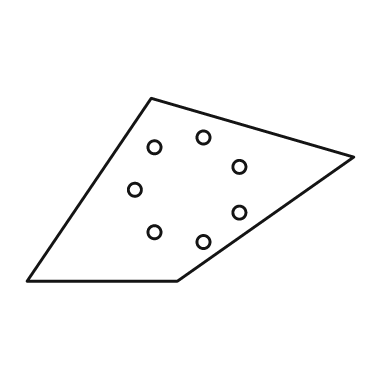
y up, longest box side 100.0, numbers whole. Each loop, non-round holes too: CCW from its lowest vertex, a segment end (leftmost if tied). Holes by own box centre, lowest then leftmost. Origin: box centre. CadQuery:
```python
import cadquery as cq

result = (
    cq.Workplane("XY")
    .moveTo(-50.0, -28.0)
    .lineTo(-4.0, -28.0)
    .lineTo(50.0, 10.0)
    .lineTo(-12.0, 28.0)
    .close()
    .moveTo(4.0, -16.0)
    .circle(2.0)
    .moveTo(-11.0, -13.0)
    .circle(2.0)
    .moveTo(15.0, -7.0)
    .circle(2.0)
    .moveTo(-17.0, 0.0)
    .circle(2.0)
    .moveTo(15.0, 7.0)
    .circle(2.0)
    .moveTo(-11.0, 13.0)
    .circle(2.0)
    .moveTo(4.0, 16.0)
    .circle(2.0)
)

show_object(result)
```